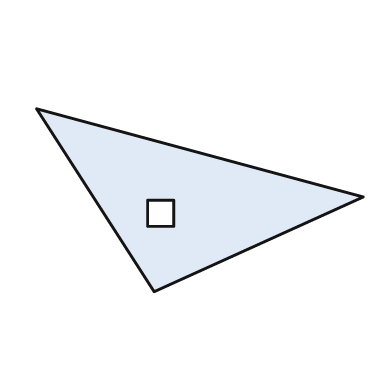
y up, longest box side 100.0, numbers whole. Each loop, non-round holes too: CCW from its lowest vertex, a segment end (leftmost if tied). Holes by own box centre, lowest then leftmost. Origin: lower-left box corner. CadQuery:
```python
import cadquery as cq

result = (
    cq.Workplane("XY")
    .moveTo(36.0, 0.0)
    .lineTo(100.0, 29.0)
    .lineTo(0.0, 56.0)
    .close()
    .moveTo(34.0, 20.0)
    .lineTo(42.0, 20.0)
    .lineTo(42.0, 28.0)
    .lineTo(34.0, 28.0)
    .close()
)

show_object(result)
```